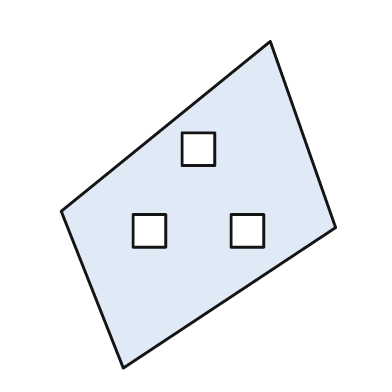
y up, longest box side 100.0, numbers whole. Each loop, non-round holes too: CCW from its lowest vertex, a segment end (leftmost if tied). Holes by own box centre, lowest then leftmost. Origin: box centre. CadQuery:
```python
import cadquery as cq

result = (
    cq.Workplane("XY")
    .moveTo(-23.0, -50.0)
    .lineTo(42.0, -7.0)
    .lineTo(22.0, 50.0)
    .lineTo(-42.0, -2.0)
    .close()
    .moveTo(-20.0, -13.0)
    .lineTo(-10.0, -13.0)
    .lineTo(-10.0, -3.0)
    .lineTo(-20.0, -3.0)
    .close()
    .moveTo(10.0, -13.0)
    .lineTo(20.0, -13.0)
    .lineTo(20.0, -3.0)
    .lineTo(10.0, -3.0)
    .close()
    .moveTo(-5.0, 12.0)
    .lineTo(5.0, 12.0)
    .lineTo(5.0, 22.0)
    .lineTo(-5.0, 22.0)
    .close()
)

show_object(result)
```